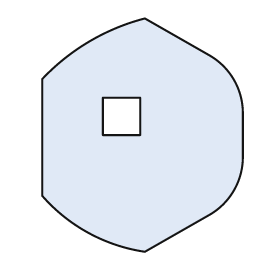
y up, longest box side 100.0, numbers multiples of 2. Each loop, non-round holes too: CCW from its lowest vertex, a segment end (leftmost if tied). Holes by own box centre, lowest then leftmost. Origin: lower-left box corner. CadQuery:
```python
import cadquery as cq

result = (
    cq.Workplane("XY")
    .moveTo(44.0, 0.0)
    .lineTo(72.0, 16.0)
    .threePointArc((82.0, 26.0), (86.0, 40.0))
    .lineTo(86.0, 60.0)
    .threePointArc((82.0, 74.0), (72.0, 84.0))
    .lineTo(44.0, 100.0)
    .threePointArc((20.0, 90.0), (0.0, 74.0))
    .lineTo(0.0, 24.0)
    .threePointArc((20.0, 8.0), (44.0, 0.0))
    .close()
    .moveTo(26.0, 50.0)
    .lineTo(42.0, 50.0)
    .lineTo(42.0, 66.0)
    .lineTo(26.0, 66.0)
    .close()
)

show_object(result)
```